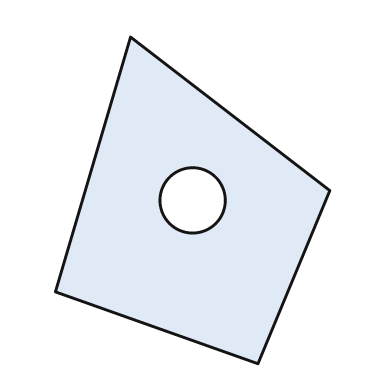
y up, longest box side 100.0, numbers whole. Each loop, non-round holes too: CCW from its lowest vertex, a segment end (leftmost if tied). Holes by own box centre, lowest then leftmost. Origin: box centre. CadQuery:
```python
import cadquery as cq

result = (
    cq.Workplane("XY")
    .moveTo(20.0, -50.0)
    .lineTo(42.0, 3.0)
    .lineTo(-19.0, 50.0)
    .lineTo(-42.0, -28.0)
    .close()
    .moveTo(0.0, 0.0)
    .circle(10.0)
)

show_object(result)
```